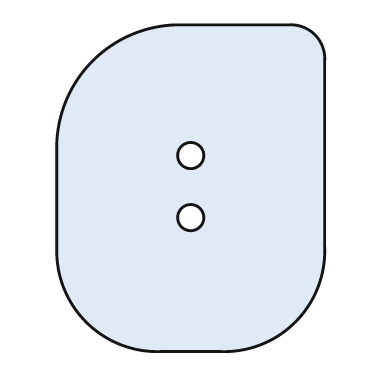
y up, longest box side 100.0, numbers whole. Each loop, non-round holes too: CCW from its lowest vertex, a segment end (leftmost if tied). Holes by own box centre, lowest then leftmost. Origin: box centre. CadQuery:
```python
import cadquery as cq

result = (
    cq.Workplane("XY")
    .moveTo(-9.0, -50.0)
    .lineTo(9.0, -50.0)
    .threePointArc((32.0, -41.0), (41.0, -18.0))
    .lineTo(41.0, 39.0)
    .threePointArc((38.0, 47.0), (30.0, 50.0))
    .lineTo(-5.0, 50.0)
    .threePointArc((-30.0, 39.0), (-41.0, 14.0))
    .lineTo(-41.0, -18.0)
    .threePointArc((-32.0, -41.0), (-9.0, -50.0))
    .close()
    .moveTo(0.0, -9.0)
    .circle(4.0)
    .moveTo(0.0, 10.0)
    .circle(4.0)
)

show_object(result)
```